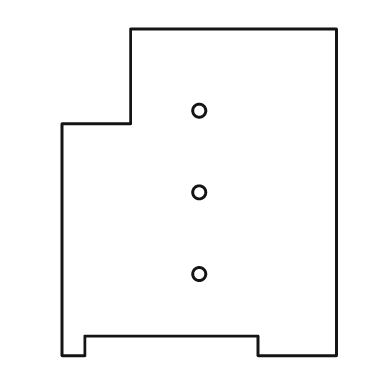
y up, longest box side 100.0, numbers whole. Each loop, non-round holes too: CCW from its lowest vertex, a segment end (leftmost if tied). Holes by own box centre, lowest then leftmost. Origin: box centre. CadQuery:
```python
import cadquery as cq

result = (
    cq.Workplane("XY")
    .moveTo(-42.0, -50.0)
    .lineTo(-35.0, -50.0)
    .lineTo(-35.0, -44.0)
    .lineTo(18.0, -44.0)
    .lineTo(18.0, -50.0)
    .lineTo(42.0, -50.0)
    .lineTo(42.0, 50.0)
    .lineTo(-21.0, 50.0)
    .lineTo(-21.0, 21.0)
    .lineTo(-42.0, 21.0)
    .close()
    .moveTo(0.0, -25.0)
    .circle(2.0)
    .moveTo(0.0, 0.0)
    .circle(2.0)
    .moveTo(0.0, 25.0)
    .circle(2.0)
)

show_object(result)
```